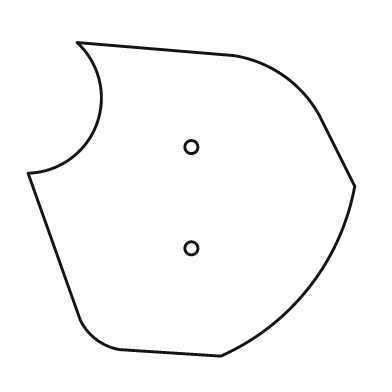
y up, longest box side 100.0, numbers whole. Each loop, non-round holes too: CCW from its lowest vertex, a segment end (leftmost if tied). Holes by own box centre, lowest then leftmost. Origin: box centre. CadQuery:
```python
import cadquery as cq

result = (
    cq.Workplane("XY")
    .moveTo(9.0, -48.0)
    .threePointArc((36.0, -27.0), (50.0, 4.0))
    .lineTo(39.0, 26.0)
    .threePointArc((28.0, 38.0), (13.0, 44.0))
    .lineTo(-35.0, 48.0)
    .threePointArc((-29.0, 23.0), (-50.0, 8.0))
    .lineTo(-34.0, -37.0)
    .threePointArc((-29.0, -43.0), (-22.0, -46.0))
    .close()
    .moveTo(0.0, -15.0)
    .circle(2.0)
    .moveTo(0.0, 16.0)
    .circle(2.0)
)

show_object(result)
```